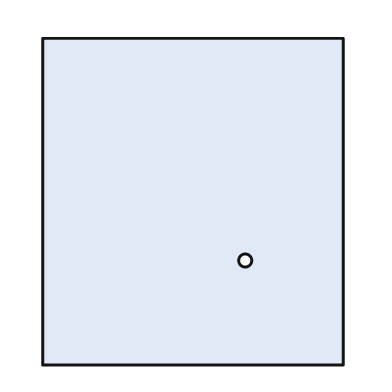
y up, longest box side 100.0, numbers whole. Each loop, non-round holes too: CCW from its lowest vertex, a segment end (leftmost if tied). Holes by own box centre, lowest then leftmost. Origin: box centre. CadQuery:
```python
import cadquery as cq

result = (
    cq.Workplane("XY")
    .moveTo(-46.0, -50.0)
    .lineTo(46.0, -50.0)
    .lineTo(46.0, 50.0)
    .lineTo(-46.0, 50.0)
    .close()
    .moveTo(16.0, -18.0)
    .circle(2.0)
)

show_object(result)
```